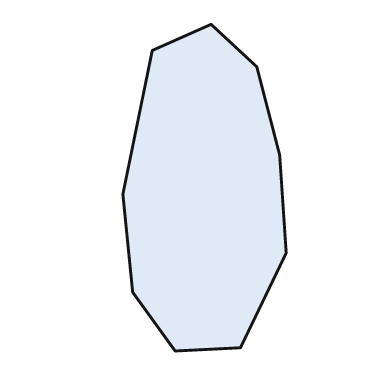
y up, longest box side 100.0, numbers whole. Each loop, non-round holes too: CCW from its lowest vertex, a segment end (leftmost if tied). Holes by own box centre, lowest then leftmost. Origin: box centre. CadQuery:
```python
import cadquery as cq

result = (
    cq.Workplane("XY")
    .moveTo(-9.0, -50.0)
    .lineTo(11.0, -49.0)
    .lineTo(25.0, -20.0)
    .lineTo(23.0, 10.0)
    .lineTo(16.0, 37.0)
    .lineTo(2.0, 50.0)
    .lineTo(-16.0, 42.0)
    .lineTo(-25.0, -2.0)
    .lineTo(-22.0, -32.0)
    .close()
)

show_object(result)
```